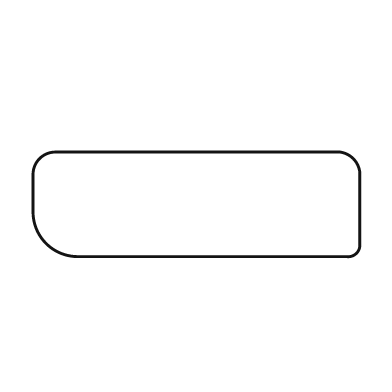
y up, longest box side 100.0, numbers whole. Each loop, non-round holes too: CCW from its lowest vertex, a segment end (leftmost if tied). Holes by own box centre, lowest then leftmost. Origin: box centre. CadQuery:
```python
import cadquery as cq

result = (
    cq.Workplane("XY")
    .moveTo(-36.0, -16.0)
    .lineTo(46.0, -16.0)
    .threePointArc((49.0, -15.0), (50.0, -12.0))
    .lineTo(50.0, 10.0)
    .threePointArc((48.0, 14.0), (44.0, 16.0))
    .lineTo(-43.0, 16.0)
    .threePointArc((-48.0, 14.0), (-50.0, 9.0))
    .lineTo(-50.0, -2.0)
    .threePointArc((-46.0, -12.0), (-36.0, -16.0))
    .close()
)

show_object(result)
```